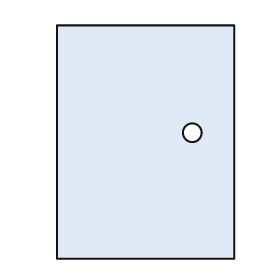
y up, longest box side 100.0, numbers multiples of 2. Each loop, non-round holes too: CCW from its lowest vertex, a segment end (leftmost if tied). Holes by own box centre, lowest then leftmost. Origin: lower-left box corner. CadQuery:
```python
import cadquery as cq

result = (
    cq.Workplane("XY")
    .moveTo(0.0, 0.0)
    .lineTo(76.0, 0.0)
    .lineTo(76.0, 100.0)
    .lineTo(0.0, 100.0)
    .close()
    .moveTo(58.0, 54.0)
    .circle(4.0)
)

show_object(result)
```